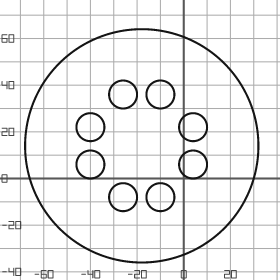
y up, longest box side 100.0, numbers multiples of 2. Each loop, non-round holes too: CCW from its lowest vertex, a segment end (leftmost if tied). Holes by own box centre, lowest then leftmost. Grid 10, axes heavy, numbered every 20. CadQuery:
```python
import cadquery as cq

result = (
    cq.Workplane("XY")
    .moveTo(-18.0, 14.0)
    .circle(50.0)
    .moveTo(-26.0, -8.0)
    .circle(6.0)
    .moveTo(-10.0, -8.0)
    .circle(6.0)
    .moveTo(-40.0, 6.0)
    .circle(6.0)
    .moveTo(4.0, 6.0)
    .circle(6.0)
    .moveTo(-40.0, 22.0)
    .circle(6.0)
    .moveTo(4.0, 22.0)
    .circle(6.0)
    .moveTo(-26.0, 36.0)
    .circle(6.0)
    .moveTo(-10.0, 36.0)
    .circle(6.0)
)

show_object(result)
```